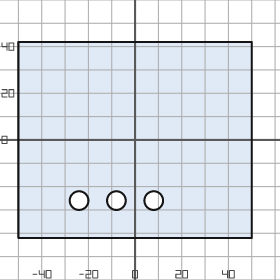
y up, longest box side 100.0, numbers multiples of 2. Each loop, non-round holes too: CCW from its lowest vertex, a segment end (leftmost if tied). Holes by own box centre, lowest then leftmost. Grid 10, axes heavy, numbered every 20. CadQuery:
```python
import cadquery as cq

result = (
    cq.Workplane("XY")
    .moveTo(-50.0, -42.0)
    .lineTo(50.0, -42.0)
    .lineTo(50.0, 42.0)
    .lineTo(-50.0, 42.0)
    .close()
    .moveTo(-24.0, -26.0)
    .circle(4.0)
    .moveTo(-8.0, -26.0)
    .circle(4.0)
    .moveTo(8.0, -26.0)
    .circle(4.0)
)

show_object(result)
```